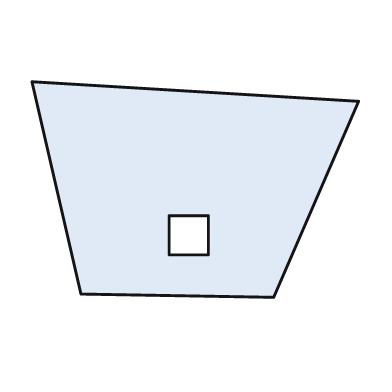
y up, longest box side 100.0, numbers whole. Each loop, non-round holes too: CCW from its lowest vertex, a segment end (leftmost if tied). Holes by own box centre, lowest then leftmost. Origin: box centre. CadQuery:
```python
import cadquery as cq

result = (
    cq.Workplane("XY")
    .moveTo(24.0, -33.0)
    .lineTo(50.0, 27.0)
    .lineTo(-50.0, 33.0)
    .lineTo(-35.0, -32.0)
    .close()
    .moveTo(-8.0, -20.0)
    .lineTo(4.0, -20.0)
    .lineTo(4.0, -8.0)
    .lineTo(-8.0, -8.0)
    .close()
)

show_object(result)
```